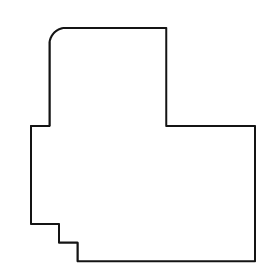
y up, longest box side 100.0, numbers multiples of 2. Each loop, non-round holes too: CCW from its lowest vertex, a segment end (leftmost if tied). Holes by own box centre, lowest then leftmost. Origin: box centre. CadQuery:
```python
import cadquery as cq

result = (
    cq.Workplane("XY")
    .moveTo(-28.0, -50.0)
    .lineTo(48.0, -50.0)
    .lineTo(48.0, 8.0)
    .lineTo(10.0, 8.0)
    .lineTo(10.0, 50.0)
    .lineTo(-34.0, 50.0)
    .threePointArc((-38.0, 48.0), (-40.0, 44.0))
    .lineTo(-40.0, 8.0)
    .lineTo(-48.0, 8.0)
    .lineTo(-48.0, -34.0)
    .lineTo(-36.0, -34.0)
    .lineTo(-36.0, -42.0)
    .lineTo(-28.0, -42.0)
    .close()
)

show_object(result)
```